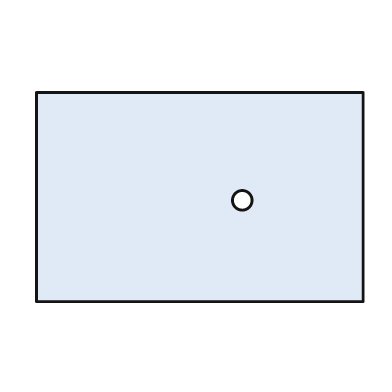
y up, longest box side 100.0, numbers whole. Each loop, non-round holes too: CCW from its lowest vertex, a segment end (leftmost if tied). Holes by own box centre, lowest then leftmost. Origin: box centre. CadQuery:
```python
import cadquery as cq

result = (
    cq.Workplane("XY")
    .moveTo(-50.0, -32.0)
    .lineTo(50.0, -32.0)
    .lineTo(50.0, 32.0)
    .lineTo(-50.0, 32.0)
    .close()
    .moveTo(13.0, -1.0)
    .circle(3.0)
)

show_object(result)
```